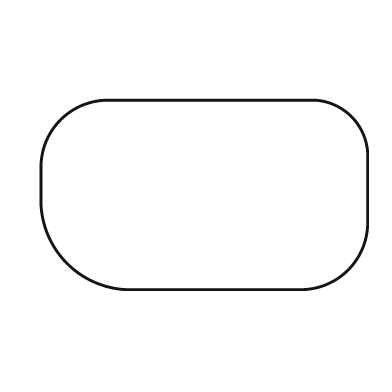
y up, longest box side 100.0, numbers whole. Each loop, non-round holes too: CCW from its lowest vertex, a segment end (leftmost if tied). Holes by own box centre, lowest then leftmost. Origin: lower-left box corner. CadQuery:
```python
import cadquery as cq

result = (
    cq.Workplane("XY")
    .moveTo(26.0, 0.0)
    .lineTo(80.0, 0.0)
    .threePointArc((94.0, 6.0), (100.0, 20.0))
    .lineTo(100.0, 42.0)
    .threePointArc((95.0, 53.0), (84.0, 58.0))
    .lineTo(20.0, 58.0)
    .threePointArc((6.0, 52.0), (0.0, 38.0))
    .lineTo(0.0, 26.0)
    .threePointArc((8.0, 8.0), (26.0, 0.0))
    .close()
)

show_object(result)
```